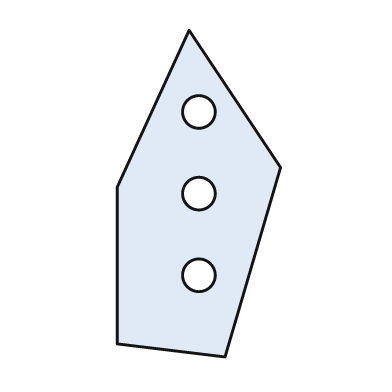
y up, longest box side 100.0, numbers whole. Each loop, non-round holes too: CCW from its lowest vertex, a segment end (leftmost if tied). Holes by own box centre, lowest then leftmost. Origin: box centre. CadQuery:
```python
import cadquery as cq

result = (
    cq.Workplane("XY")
    .moveTo(8.0, -50.0)
    .lineTo(25.0, 8.0)
    .lineTo(-3.0, 50.0)
    .lineTo(-25.0, 2.0)
    .lineTo(-25.0, -46.0)
    .close()
    .moveTo(0.0, -25.0)
    .circle(5.0)
    .moveTo(0.0, 0.0)
    .circle(5.0)
    .moveTo(0.0, 25.0)
    .circle(5.0)
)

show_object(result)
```